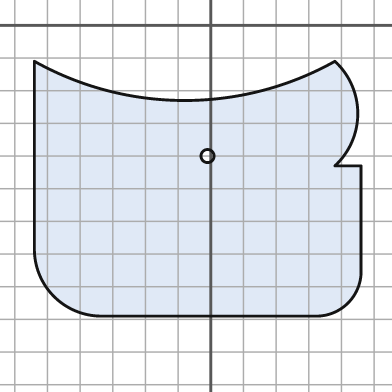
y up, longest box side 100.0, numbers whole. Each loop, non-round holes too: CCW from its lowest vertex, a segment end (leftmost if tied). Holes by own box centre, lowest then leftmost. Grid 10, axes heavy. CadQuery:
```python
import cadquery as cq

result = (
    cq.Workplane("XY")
    .moveTo(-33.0, -89.0)
    .lineTo(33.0, -89.0)
    .threePointArc((42.0, -85.0), (46.0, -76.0))
    .lineTo(46.0, -43.0)
    .lineTo(38.0, -43.0)
    .threePointArc((45.0, -27.0), (38.0, -11.0))
    .threePointArc((-8.0, -23.0), (-54.0, -11.0))
    .lineTo(-54.0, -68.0)
    .threePointArc((-48.0, -83.0), (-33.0, -89.0))
    .close()
    .moveTo(-1.0, -40.0)
    .circle(2.0)
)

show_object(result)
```